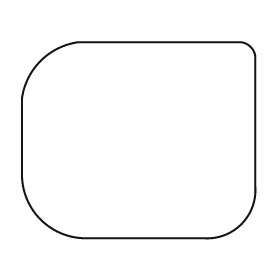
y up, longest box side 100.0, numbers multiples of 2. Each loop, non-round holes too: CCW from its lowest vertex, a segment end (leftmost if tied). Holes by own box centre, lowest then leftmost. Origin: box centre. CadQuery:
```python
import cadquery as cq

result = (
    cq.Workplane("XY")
    .moveTo(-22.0, -42.0)
    .lineTo(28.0, -42.0)
    .threePointArc((44.0, -36.0), (50.0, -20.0))
    .lineTo(50.0, 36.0)
    .threePointArc((48.0, 40.0), (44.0, 42.0))
    .lineTo(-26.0, 42.0)
    .threePointArc((-42.0, 34.0), (-50.0, 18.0))
    .lineTo(-50.0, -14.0)
    .threePointArc((-42.0, -34.0), (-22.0, -42.0))
    .close()
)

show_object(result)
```